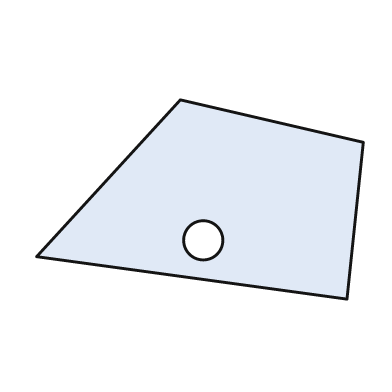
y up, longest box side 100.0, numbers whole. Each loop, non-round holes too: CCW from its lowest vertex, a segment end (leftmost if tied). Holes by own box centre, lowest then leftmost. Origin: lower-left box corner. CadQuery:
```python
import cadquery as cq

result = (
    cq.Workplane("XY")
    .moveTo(95.0, 0.0)
    .lineTo(100.0, 48.0)
    .lineTo(44.0, 61.0)
    .lineTo(0.0, 13.0)
    .close()
    .moveTo(51.0, 18.0)
    .circle(6.0)
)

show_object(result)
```